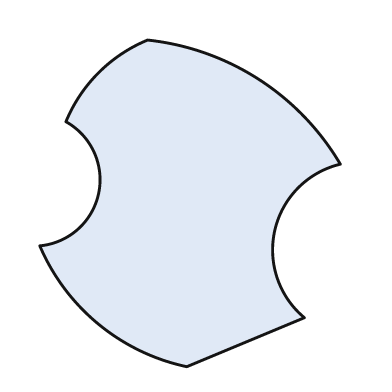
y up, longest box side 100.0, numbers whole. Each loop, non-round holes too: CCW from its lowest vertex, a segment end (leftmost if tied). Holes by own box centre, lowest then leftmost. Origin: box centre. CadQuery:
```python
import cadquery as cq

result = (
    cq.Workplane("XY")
    .moveTo(-1.0, -50.0)
    .lineTo(35.0, -35.0)
    .threePointArc((26.0, -8.0), (46.0, 12.0))
    .threePointArc((21.0, 38.0), (-13.0, 50.0))
    .threePointArc((-28.0, 40.0), (-38.0, 25.0))
    .threePointArc((-28.0, 3.0), (-46.0, -13.0))
    .threePointArc((-28.0, -37.0), (-1.0, -50.0))
    .close()
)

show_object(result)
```